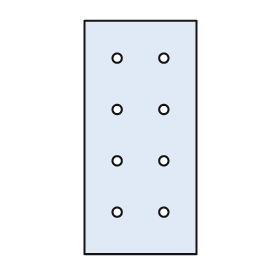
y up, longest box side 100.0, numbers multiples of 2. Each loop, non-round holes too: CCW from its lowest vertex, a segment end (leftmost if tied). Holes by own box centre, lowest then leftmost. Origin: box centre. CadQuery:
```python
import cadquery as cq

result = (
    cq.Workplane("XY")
    .moveTo(-24.0, -50.0)
    .lineTo(24.0, -50.0)
    .lineTo(24.0, 50.0)
    .lineTo(-24.0, 50.0)
    .close()
    .moveTo(-10.0, -32.0)
    .circle(2.0)
    .moveTo(10.0, -32.0)
    .circle(2.0)
    .moveTo(-10.0, -10.0)
    .circle(2.0)
    .moveTo(10.0, -10.0)
    .circle(2.0)
    .moveTo(-10.0, 12.0)
    .circle(2.0)
    .moveTo(10.0, 12.0)
    .circle(2.0)
    .moveTo(-10.0, 34.0)
    .circle(2.0)
    .moveTo(10.0, 34.0)
    .circle(2.0)
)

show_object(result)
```